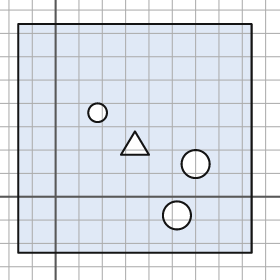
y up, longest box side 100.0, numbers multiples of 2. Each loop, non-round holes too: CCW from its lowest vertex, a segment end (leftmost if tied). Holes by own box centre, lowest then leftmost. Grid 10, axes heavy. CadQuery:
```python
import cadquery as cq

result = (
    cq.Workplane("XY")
    .moveTo(-16.0, -24.0)
    .lineTo(84.0, -24.0)
    .lineTo(84.0, 74.0)
    .lineTo(-16.0, 74.0)
    .close()
    .moveTo(52.0, -8.0)
    .circle(6.0)
    .moveTo(60.0, 14.0)
    .circle(6.0)
    .moveTo(28.0, 18.0)
    .lineTo(40.0, 18.0)
    .lineTo(34.0, 28.0)
    .close()
    .moveTo(18.0, 36.0)
    .circle(4.0)
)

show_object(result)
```